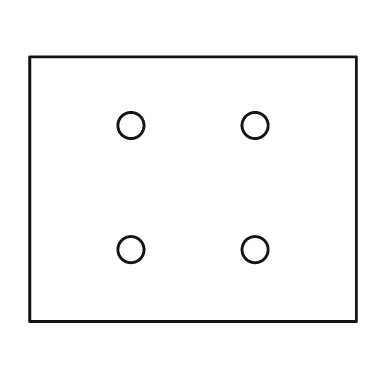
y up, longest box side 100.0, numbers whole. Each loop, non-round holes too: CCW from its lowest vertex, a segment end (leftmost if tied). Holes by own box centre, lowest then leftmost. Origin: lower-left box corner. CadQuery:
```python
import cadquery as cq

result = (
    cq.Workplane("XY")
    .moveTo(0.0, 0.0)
    .lineTo(100.0, 0.0)
    .lineTo(100.0, 81.0)
    .lineTo(0.0, 81.0)
    .close()
    .moveTo(31.0, 22.0)
    .circle(4.0)
    .moveTo(69.0, 22.0)
    .circle(4.0)
    .moveTo(31.0, 60.0)
    .circle(4.0)
    .moveTo(69.0, 60.0)
    .circle(4.0)
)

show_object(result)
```